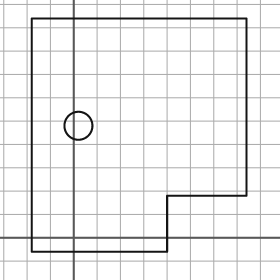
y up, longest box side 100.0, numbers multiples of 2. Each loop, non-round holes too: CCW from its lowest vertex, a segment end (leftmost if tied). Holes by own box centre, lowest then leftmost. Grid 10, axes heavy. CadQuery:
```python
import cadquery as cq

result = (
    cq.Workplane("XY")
    .moveTo(-18.0, -6.0)
    .lineTo(40.0, -6.0)
    .lineTo(40.0, 18.0)
    .lineTo(74.0, 18.0)
    .lineTo(74.0, 94.0)
    .lineTo(-18.0, 94.0)
    .close()
    .moveTo(2.0, 48.0)
    .circle(6.0)
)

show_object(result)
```